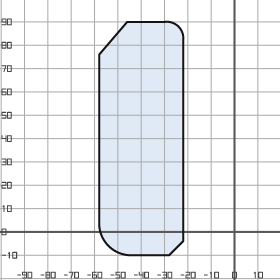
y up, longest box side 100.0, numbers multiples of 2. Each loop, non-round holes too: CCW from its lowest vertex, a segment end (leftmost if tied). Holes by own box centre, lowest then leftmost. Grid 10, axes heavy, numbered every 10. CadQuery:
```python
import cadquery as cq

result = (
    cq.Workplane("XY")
    .moveTo(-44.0, -10.0)
    .lineTo(-28.0, -10.0)
    .lineTo(-22.0, -4.0)
    .lineTo(-22.0, 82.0)
    .threePointArc((-24.0, 88.0), (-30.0, 90.0))
    .lineTo(-46.0, 90.0)
    .lineTo(-58.0, 76.0)
    .lineTo(-58.0, 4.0)
    .threePointArc((-54.0, -6.0), (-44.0, -10.0))
    .close()
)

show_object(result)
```